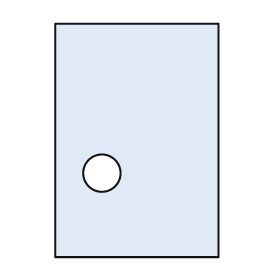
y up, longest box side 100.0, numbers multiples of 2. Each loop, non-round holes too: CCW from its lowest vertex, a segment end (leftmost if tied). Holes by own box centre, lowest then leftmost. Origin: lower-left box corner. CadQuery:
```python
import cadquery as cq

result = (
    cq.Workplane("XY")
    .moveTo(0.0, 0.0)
    .lineTo(70.0, 0.0)
    .lineTo(70.0, 100.0)
    .lineTo(0.0, 100.0)
    .close()
    .moveTo(20.0, 36.0)
    .circle(8.0)
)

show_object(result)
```